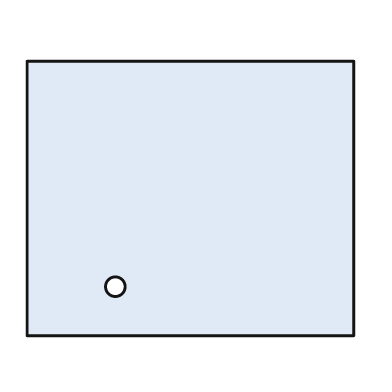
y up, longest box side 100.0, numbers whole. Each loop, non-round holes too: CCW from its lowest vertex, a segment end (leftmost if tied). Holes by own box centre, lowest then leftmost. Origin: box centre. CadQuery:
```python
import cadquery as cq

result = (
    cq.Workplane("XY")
    .moveTo(-50.0, -42.0)
    .lineTo(50.0, -42.0)
    .lineTo(50.0, 42.0)
    .lineTo(-50.0, 42.0)
    .close()
    .moveTo(-23.0, -27.0)
    .circle(3.0)
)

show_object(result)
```